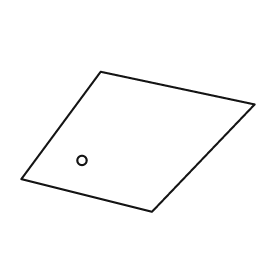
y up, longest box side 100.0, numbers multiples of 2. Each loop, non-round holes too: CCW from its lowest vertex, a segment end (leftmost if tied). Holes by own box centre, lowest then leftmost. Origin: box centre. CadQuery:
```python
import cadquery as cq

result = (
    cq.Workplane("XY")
    .moveTo(6.0, -30.0)
    .lineTo(50.0, 16.0)
    .lineTo(-16.0, 30.0)
    .lineTo(-50.0, -16.0)
    .close()
    .moveTo(-24.0, -8.0)
    .circle(2.0)
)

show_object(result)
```